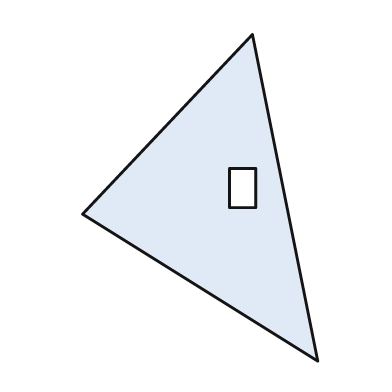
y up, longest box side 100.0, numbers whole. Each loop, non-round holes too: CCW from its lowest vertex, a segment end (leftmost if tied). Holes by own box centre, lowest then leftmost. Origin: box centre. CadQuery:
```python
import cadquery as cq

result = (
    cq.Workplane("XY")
    .moveTo(36.0, -50.0)
    .lineTo(16.0, 50.0)
    .lineTo(-36.0, -5.0)
    .close()
    .moveTo(9.0, -3.0)
    .lineTo(17.0, -3.0)
    .lineTo(17.0, 9.0)
    .lineTo(9.0, 9.0)
    .close()
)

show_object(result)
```